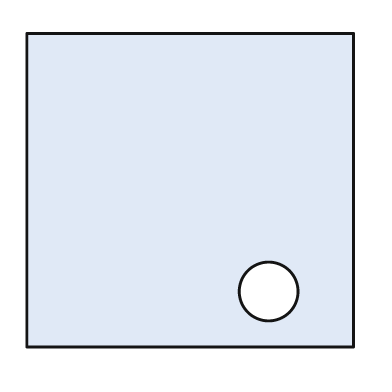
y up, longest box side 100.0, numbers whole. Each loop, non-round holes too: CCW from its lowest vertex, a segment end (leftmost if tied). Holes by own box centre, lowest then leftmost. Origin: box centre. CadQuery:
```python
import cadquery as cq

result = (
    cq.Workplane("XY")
    .moveTo(-50.0, -48.0)
    .lineTo(50.0, -48.0)
    .lineTo(50.0, 48.0)
    .lineTo(-50.0, 48.0)
    .close()
    .moveTo(24.0, -31.0)
    .circle(9.0)
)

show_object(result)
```